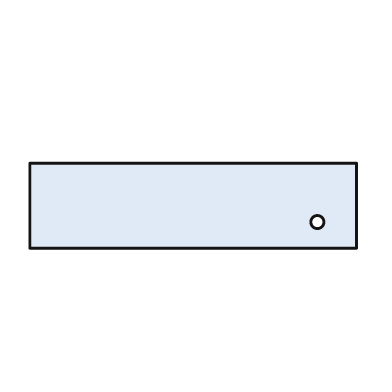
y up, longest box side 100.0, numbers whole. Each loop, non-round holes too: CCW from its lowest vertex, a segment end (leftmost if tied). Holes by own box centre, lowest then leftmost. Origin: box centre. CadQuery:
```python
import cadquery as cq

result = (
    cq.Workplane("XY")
    .moveTo(-50.0, -13.0)
    .lineTo(50.0, -13.0)
    .lineTo(50.0, 13.0)
    .lineTo(-50.0, 13.0)
    .close()
    .moveTo(38.0, -5.0)
    .circle(2.0)
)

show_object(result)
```